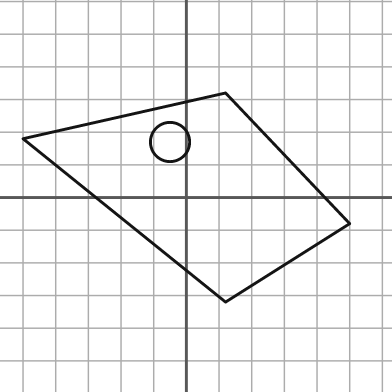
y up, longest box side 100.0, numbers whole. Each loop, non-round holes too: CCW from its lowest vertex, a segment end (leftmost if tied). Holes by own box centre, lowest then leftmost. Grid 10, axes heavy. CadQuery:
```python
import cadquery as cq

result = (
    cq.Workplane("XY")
    .moveTo(12.0, -32.0)
    .lineTo(50.0, -8.0)
    .lineTo(12.0, 32.0)
    .lineTo(-50.0, 18.0)
    .close()
    .moveTo(-5.0, 17.0)
    .circle(6.0)
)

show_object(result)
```